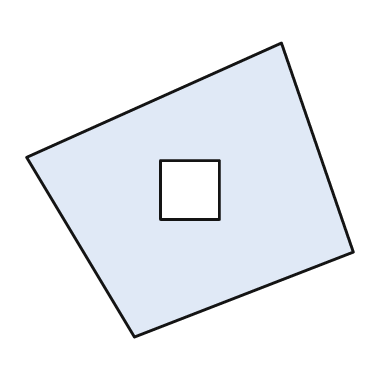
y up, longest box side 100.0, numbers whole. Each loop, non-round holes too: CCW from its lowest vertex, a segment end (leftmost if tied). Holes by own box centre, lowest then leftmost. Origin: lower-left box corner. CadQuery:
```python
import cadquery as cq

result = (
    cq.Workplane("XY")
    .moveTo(33.0, 0.0)
    .lineTo(100.0, 26.0)
    .lineTo(78.0, 90.0)
    .lineTo(0.0, 55.0)
    .close()
    .moveTo(41.0, 36.0)
    .lineTo(59.0, 36.0)
    .lineTo(59.0, 54.0)
    .lineTo(41.0, 54.0)
    .close()
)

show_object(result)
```